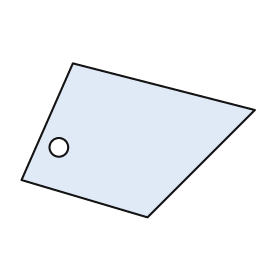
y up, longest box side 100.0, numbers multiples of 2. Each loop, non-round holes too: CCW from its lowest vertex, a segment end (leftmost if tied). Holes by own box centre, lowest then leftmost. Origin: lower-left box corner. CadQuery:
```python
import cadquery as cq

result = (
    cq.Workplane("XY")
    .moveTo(54.0, 0.0)
    .lineTo(100.0, 46.0)
    .lineTo(22.0, 66.0)
    .lineTo(0.0, 16.0)
    .close()
    .moveTo(16.0, 30.0)
    .circle(4.0)
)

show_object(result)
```